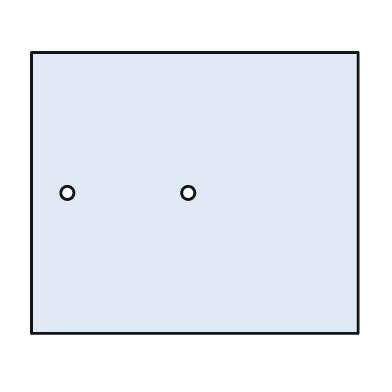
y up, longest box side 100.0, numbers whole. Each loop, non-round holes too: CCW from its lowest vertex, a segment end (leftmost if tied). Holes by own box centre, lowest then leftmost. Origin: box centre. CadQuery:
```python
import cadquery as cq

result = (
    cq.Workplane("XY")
    .moveTo(-50.0, -43.0)
    .lineTo(50.0, -43.0)
    .lineTo(50.0, 43.0)
    .lineTo(-50.0, 43.0)
    .close()
    .moveTo(-39.0, 0.0)
    .circle(2.0)
    .moveTo(-2.0, 0.0)
    .circle(2.0)
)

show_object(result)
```